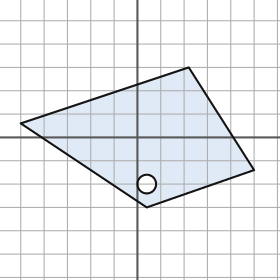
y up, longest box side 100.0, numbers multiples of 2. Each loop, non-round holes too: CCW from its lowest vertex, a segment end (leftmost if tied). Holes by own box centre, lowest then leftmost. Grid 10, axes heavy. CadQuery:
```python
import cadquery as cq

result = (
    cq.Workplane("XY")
    .moveTo(4.0, -30.0)
    .lineTo(50.0, -14.0)
    .lineTo(22.0, 30.0)
    .lineTo(-50.0, 6.0)
    .close()
    .moveTo(4.0, -20.0)
    .circle(4.0)
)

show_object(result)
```